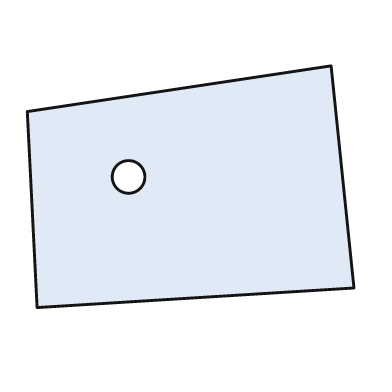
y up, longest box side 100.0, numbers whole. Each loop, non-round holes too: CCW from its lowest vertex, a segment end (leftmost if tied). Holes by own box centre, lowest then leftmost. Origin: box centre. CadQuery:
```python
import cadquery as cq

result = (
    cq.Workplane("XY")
    .moveTo(-47.0, -37.0)
    .lineTo(50.0, -31.0)
    .lineTo(43.0, 37.0)
    .lineTo(-50.0, 23.0)
    .close()
    .moveTo(-19.0, 3.0)
    .circle(5.0)
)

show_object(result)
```